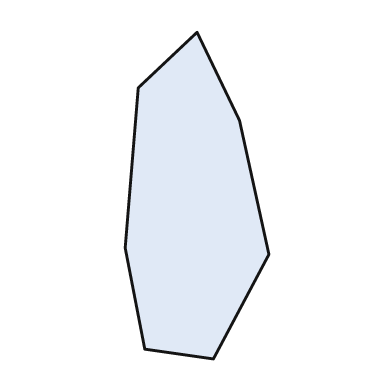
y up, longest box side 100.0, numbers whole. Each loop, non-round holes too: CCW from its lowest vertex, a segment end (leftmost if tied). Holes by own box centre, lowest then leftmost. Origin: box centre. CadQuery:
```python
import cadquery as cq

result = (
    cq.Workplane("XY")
    .moveTo(5.0, -50.0)
    .lineTo(22.0, -18.0)
    .lineTo(13.0, 23.0)
    .lineTo(0.0, 50.0)
    .lineTo(-18.0, 33.0)
    .lineTo(-22.0, -16.0)
    .lineTo(-16.0, -47.0)
    .close()
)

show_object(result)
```